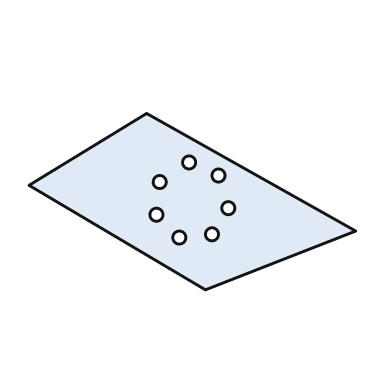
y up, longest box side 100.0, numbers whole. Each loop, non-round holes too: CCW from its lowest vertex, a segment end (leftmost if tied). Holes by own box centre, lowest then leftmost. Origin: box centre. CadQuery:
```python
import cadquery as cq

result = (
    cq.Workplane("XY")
    .moveTo(4.0, -27.0)
    .lineTo(50.0, -9.0)
    .lineTo(-14.0, 27.0)
    .lineTo(-50.0, 5.0)
    .close()
    .moveTo(-4.0, -11.0)
    .circle(2.0)
    .moveTo(6.0, -10.0)
    .circle(2.0)
    .moveTo(-11.0, -4.0)
    .circle(2.0)
    .moveTo(11.0, -2.0)
    .circle(2.0)
    .moveTo(-10.0, 6.0)
    .circle(2.0)
    .moveTo(8.0, 8.0)
    .circle(2.0)
    .moveTo(-1.0, 12.0)
    .circle(2.0)
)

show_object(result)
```